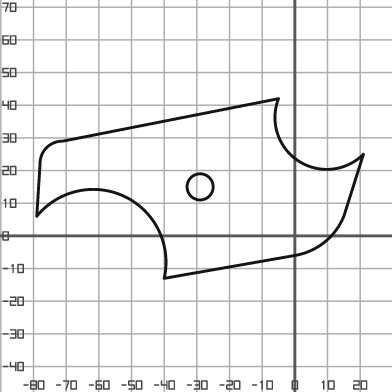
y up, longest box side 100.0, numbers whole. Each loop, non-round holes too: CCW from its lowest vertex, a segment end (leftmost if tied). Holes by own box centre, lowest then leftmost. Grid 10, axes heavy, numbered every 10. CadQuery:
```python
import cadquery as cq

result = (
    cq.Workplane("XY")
    .moveTo(-40.0, -13.0)
    .lineTo(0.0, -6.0)
    .threePointArc((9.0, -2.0), (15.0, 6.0))
    .lineTo(21.0, 25.0)
    .threePointArc((1.0, 23.0), (-5.0, 42.0))
    .lineTo(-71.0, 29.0)
    .threePointArc((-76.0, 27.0), (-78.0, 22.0))
    .lineTo(-79.0, 6.0)
    .threePointArc((-52.0, 12.0), (-40.0, -13.0))
    .close()
    .moveTo(-29.0, 15.0)
    .circle(4.0)
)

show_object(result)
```